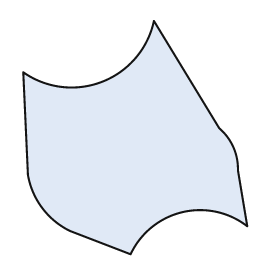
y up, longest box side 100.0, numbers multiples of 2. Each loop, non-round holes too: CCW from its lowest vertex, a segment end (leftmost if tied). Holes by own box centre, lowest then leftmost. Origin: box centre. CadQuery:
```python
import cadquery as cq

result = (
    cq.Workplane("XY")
    .moveTo(-2.0, -50.0)
    .threePointArc((20.0, -32.0), (48.0, -38.0))
    .lineTo(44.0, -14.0)
    .threePointArc((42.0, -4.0), (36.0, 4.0))
    .lineTo(8.0, 50.0)
    .threePointArc((-14.0, 24.0), (-48.0, 28.0))
    .lineTo(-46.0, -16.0)
    .threePointArc((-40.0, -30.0), (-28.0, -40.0))
    .close()
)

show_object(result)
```